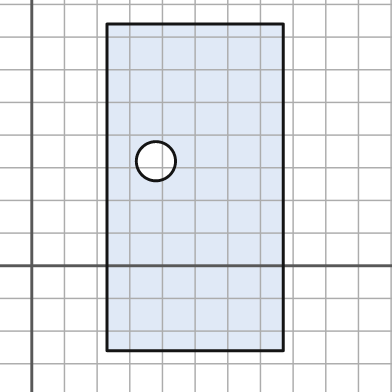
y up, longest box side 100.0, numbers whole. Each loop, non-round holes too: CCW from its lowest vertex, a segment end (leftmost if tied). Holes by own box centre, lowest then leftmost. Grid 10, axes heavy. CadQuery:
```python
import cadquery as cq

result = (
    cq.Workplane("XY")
    .moveTo(23.0, -26.0)
    .lineTo(77.0, -26.0)
    .lineTo(77.0, 74.0)
    .lineTo(23.0, 74.0)
    .close()
    .moveTo(38.0, 32.0)
    .circle(6.0)
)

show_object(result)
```